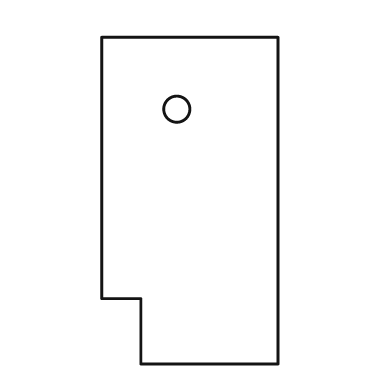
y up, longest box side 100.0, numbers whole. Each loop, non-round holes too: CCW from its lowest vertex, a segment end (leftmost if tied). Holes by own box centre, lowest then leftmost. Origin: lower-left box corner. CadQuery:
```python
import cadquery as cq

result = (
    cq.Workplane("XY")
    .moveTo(12.0, 0.0)
    .lineTo(54.0, 0.0)
    .lineTo(54.0, 100.0)
    .lineTo(0.0, 100.0)
    .lineTo(0.0, 20.0)
    .lineTo(12.0, 20.0)
    .close()
    .moveTo(23.0, 78.0)
    .circle(4.0)
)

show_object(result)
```